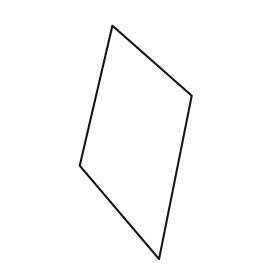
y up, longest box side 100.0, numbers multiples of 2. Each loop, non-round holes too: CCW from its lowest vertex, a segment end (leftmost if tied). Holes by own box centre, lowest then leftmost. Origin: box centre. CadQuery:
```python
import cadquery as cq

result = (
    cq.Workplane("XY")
    .moveTo(10.0, -50.0)
    .lineTo(24.0, 20.0)
    .lineTo(-10.0, 50.0)
    .lineTo(-24.0, -10.0)
    .close()
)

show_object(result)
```